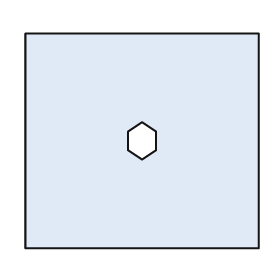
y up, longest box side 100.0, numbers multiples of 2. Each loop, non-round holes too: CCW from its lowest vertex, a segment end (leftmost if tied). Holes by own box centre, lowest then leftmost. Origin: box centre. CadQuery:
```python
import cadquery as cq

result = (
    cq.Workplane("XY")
    .moveTo(-50.0, -46.0)
    .lineTo(50.0, -46.0)
    .lineTo(50.0, 46.0)
    .lineTo(-50.0, 46.0)
    .close()
    .moveTo(0.0, -8.0)
    .lineTo(6.0, -4.0)
    .lineTo(6.0, 4.0)
    .lineTo(0.0, 8.0)
    .lineTo(-6.0, 4.0)
    .lineTo(-6.0, -4.0)
    .close()
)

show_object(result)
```